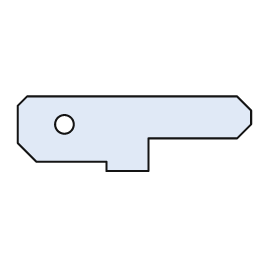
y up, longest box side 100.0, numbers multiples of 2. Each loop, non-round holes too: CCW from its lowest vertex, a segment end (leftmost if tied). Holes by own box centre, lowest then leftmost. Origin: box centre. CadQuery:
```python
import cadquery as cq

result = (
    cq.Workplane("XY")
    .moveTo(-12.0, -16.0)
    .lineTo(6.0, -16.0)
    .lineTo(6.0, -2.0)
    .lineTo(44.0, -2.0)
    .lineTo(50.0, 4.0)
    .lineTo(50.0, 10.0)
    .lineTo(44.0, 16.0)
    .lineTo(-46.0, 16.0)
    .lineTo(-50.0, 12.0)
    .lineTo(-50.0, -4.0)
    .lineTo(-42.0, -12.0)
    .lineTo(-12.0, -12.0)
    .close()
    .moveTo(-30.0, 4.0)
    .circle(4.0)
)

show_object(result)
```